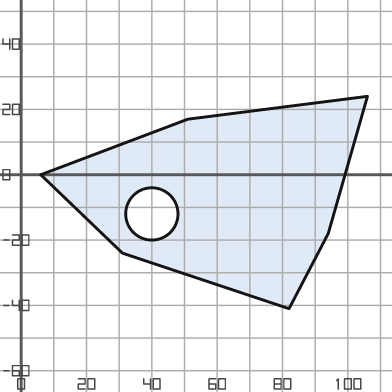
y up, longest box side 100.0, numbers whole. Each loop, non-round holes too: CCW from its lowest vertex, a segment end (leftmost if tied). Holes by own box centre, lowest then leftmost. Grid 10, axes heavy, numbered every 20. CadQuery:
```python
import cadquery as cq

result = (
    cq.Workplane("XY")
    .moveTo(82.0, -41.0)
    .lineTo(94.0, -18.0)
    .lineTo(106.0, 24.0)
    .lineTo(51.0, 17.0)
    .lineTo(6.0, 0.0)
    .lineTo(31.0, -24.0)
    .close()
    .moveTo(40.0, -12.0)
    .circle(8.0)
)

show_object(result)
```